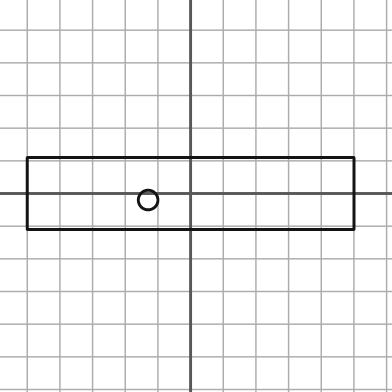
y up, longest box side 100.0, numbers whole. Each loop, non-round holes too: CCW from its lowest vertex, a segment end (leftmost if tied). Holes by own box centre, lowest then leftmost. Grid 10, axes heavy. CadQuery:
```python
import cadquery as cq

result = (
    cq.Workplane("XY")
    .moveTo(-50.0, -11.0)
    .lineTo(50.0, -11.0)
    .lineTo(50.0, 11.0)
    .lineTo(-50.0, 11.0)
    .close()
    .moveTo(-13.0, -2.0)
    .circle(3.0)
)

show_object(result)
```